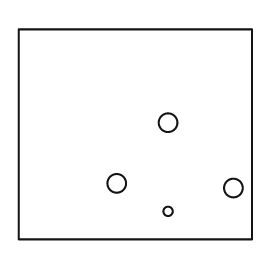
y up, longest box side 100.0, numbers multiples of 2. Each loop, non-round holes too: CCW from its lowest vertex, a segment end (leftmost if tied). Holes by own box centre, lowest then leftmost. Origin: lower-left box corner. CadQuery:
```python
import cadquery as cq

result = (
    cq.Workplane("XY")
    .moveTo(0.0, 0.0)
    .lineTo(100.0, 0.0)
    .lineTo(100.0, 90.0)
    .lineTo(0.0, 90.0)
    .close()
    .moveTo(64.0, 12.0)
    .circle(2.0)
    .moveTo(92.0, 22.0)
    .circle(4.0)
    .moveTo(42.0, 24.0)
    .circle(4.0)
    .moveTo(64.0, 50.0)
    .circle(4.0)
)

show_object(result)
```